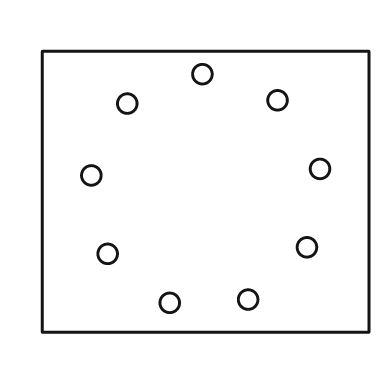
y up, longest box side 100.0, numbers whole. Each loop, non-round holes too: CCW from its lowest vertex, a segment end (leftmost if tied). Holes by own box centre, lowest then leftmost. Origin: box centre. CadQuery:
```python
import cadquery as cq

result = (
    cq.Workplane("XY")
    .moveTo(-50.0, -43.0)
    .lineTo(50.0, -43.0)
    .lineTo(50.0, 43.0)
    .lineTo(-50.0, 43.0)
    .close()
    .moveTo(-11.0, -34.0)
    .circle(3.0)
    .moveTo(13.0, -33.0)
    .circle(3.0)
    .moveTo(-30.0, -19.0)
    .circle(3.0)
    .moveTo(31.0, -17.0)
    .circle(3.0)
    .moveTo(-35.0, 5.0)
    .circle(3.0)
    .moveTo(35.0, 7.0)
    .circle(3.0)
    .moveTo(-24.0, 27.0)
    .circle(3.0)
    .moveTo(22.0, 28.0)
    .circle(3.0)
    .moveTo(-1.0, 36.0)
    .circle(3.0)
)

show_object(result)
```